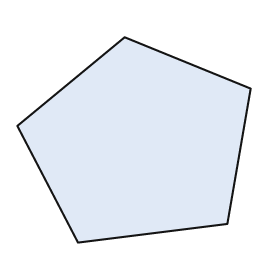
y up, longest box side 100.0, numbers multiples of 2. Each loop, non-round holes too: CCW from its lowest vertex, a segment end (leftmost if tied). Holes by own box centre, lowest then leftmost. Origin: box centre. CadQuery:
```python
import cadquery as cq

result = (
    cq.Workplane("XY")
    .moveTo(-24.0, -44.0)
    .lineTo(40.0, -36.0)
    .lineTo(50.0, 22.0)
    .lineTo(-4.0, 44.0)
    .lineTo(-50.0, 6.0)
    .close()
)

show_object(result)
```